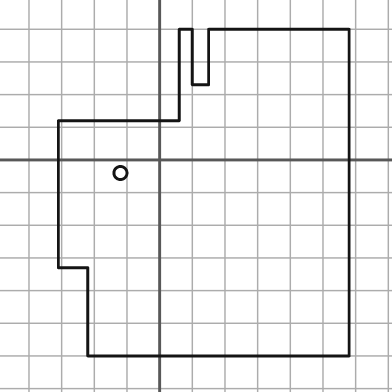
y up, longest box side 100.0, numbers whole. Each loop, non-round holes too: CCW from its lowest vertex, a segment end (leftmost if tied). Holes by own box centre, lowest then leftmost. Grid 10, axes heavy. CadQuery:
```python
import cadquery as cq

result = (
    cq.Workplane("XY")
    .moveTo(-22.0, -60.0)
    .lineTo(58.0, -60.0)
    .lineTo(58.0, 40.0)
    .lineTo(15.0, 40.0)
    .lineTo(15.0, 23.0)
    .lineTo(10.0, 23.0)
    .lineTo(10.0, 40.0)
    .lineTo(6.0, 40.0)
    .lineTo(6.0, 12.0)
    .lineTo(-31.0, 12.0)
    .lineTo(-31.0, -33.0)
    .lineTo(-22.0, -33.0)
    .close()
    .moveTo(-12.0, -4.0)
    .circle(2.0)
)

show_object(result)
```